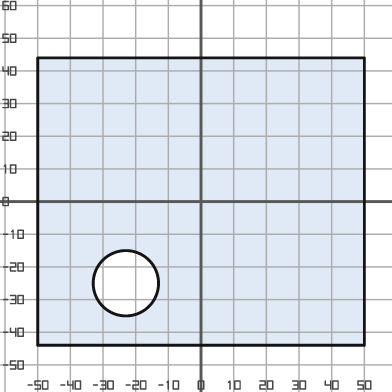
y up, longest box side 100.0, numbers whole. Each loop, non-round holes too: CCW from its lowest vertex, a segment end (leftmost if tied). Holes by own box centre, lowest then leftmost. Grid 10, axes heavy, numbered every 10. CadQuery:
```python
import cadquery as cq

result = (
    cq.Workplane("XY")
    .moveTo(-50.0, -44.0)
    .lineTo(50.0, -44.0)
    .lineTo(50.0, 44.0)
    .lineTo(-50.0, 44.0)
    .close()
    .moveTo(-23.0, -25.0)
    .circle(10.0)
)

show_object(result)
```